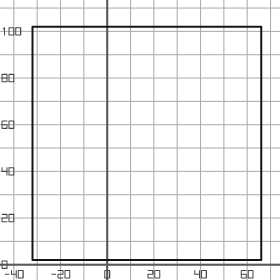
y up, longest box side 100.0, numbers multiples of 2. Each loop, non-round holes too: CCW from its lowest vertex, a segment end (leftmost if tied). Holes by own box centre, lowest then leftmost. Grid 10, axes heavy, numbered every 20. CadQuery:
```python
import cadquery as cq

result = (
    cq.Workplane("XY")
    .moveTo(-32.0, 2.0)
    .lineTo(66.0, 2.0)
    .lineTo(66.0, 102.0)
    .lineTo(-32.0, 102.0)
    .close()
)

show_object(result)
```